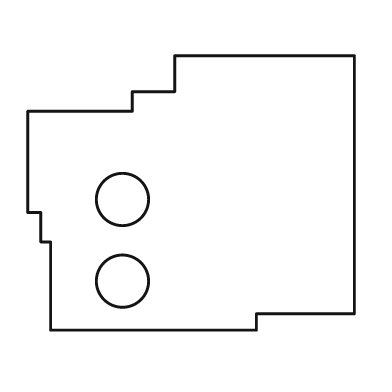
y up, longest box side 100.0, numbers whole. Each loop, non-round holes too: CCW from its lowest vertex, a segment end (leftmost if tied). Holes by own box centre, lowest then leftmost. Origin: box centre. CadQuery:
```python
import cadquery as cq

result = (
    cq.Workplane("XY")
    .moveTo(-43.0, -42.0)
    .lineTo(20.0, -42.0)
    .lineTo(20.0, -37.0)
    .lineTo(50.0, -37.0)
    .lineTo(50.0, 42.0)
    .lineTo(-5.0, 42.0)
    .lineTo(-5.0, 31.0)
    .lineTo(-18.0, 31.0)
    .lineTo(-18.0, 25.0)
    .lineTo(-50.0, 25.0)
    .lineTo(-50.0, -6.0)
    .lineTo(-46.0, -6.0)
    .lineTo(-46.0, -15.0)
    .lineTo(-43.0, -15.0)
    .close()
    .moveTo(-21.0, -27.0)
    .circle(8.0)
    .moveTo(-21.0, -2.0)
    .circle(8.0)
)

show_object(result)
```